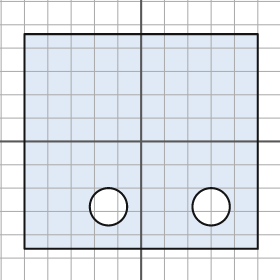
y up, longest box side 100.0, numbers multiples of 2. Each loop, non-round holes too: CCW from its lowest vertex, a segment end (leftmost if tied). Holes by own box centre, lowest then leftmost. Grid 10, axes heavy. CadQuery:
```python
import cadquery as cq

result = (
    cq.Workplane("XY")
    .moveTo(-50.0, -46.0)
    .lineTo(50.0, -46.0)
    .lineTo(50.0, 46.0)
    .lineTo(-50.0, 46.0)
    .close()
    .moveTo(-14.0, -28.0)
    .circle(8.0)
    .moveTo(30.0, -28.0)
    .circle(8.0)
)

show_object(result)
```